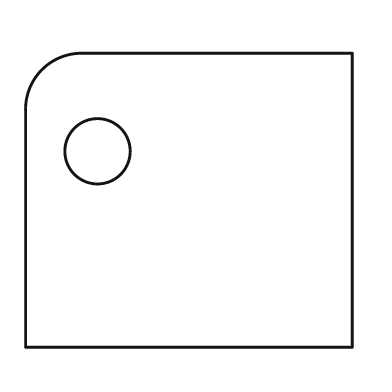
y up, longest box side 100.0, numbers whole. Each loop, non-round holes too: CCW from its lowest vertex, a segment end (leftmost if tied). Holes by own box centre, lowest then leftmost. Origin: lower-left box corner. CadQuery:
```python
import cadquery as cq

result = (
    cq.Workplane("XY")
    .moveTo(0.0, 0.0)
    .lineTo(100.0, 0.0)
    .lineTo(100.0, 90.0)
    .lineTo(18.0, 90.0)
    .threePointArc((5.0, 85.0), (0.0, 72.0))
    .close()
    .moveTo(22.0, 60.0)
    .circle(10.0)
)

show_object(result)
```